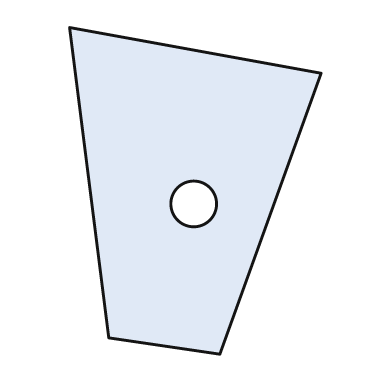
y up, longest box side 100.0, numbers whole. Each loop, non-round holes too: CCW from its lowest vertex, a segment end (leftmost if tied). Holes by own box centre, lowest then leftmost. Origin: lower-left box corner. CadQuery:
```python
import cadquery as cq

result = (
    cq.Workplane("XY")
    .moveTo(46.0, 0.0)
    .lineTo(77.0, 86.0)
    .lineTo(0.0, 100.0)
    .lineTo(12.0, 5.0)
    .close()
    .moveTo(38.0, 46.0)
    .circle(7.0)
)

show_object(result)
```